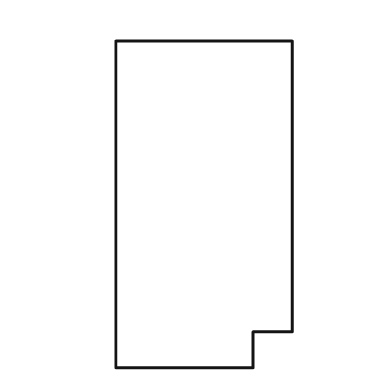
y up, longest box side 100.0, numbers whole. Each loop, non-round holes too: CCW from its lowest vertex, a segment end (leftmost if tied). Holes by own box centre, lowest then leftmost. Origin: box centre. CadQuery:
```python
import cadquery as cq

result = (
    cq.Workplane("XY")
    .moveTo(-27.0, -50.0)
    .lineTo(15.0, -50.0)
    .lineTo(15.0, -39.0)
    .lineTo(27.0, -39.0)
    .lineTo(27.0, 50.0)
    .lineTo(-27.0, 50.0)
    .close()
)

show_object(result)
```